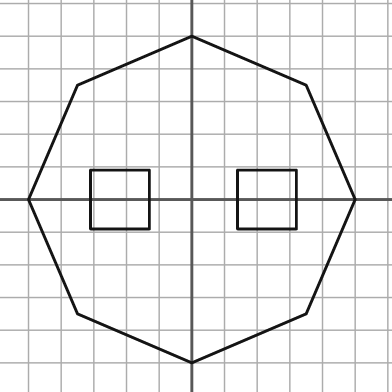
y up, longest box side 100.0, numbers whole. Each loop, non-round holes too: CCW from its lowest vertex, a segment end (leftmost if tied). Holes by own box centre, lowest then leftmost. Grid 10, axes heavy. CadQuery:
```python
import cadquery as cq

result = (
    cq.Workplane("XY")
    .moveTo(0.0, -50.0)
    .lineTo(35.0, -35.0)
    .lineTo(50.0, 0.0)
    .lineTo(35.0, 35.0)
    .lineTo(0.0, 50.0)
    .lineTo(-35.0, 35.0)
    .lineTo(-50.0, 0.0)
    .lineTo(-35.0, -35.0)
    .close()
    .moveTo(-31.0, -9.0)
    .lineTo(-13.0, -9.0)
    .lineTo(-13.0, 9.0)
    .lineTo(-31.0, 9.0)
    .close()
    .moveTo(14.0, -9.0)
    .lineTo(32.0, -9.0)
    .lineTo(32.0, 9.0)
    .lineTo(14.0, 9.0)
    .close()
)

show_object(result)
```